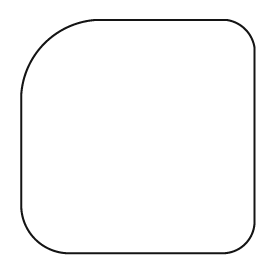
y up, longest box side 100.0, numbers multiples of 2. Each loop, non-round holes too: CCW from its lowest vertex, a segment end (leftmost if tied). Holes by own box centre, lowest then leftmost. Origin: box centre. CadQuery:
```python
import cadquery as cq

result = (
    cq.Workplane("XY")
    .moveTo(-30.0, -50.0)
    .lineTo(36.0, -50.0)
    .threePointArc((46.0, -46.0), (50.0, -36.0))
    .lineTo(50.0, 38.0)
    .threePointArc((46.0, 46.0), (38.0, 50.0))
    .lineTo(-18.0, 50.0)
    .threePointArc((-40.0, 40.0), (-50.0, 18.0))
    .lineTo(-50.0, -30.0)
    .threePointArc((-44.0, -44.0), (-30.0, -50.0))
    .close()
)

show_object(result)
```